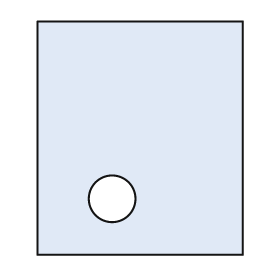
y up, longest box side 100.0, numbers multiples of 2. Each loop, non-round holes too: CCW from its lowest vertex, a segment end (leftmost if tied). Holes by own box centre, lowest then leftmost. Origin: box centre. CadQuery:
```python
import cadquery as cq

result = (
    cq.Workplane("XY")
    .moveTo(-44.0, -50.0)
    .lineTo(44.0, -50.0)
    .lineTo(44.0, 50.0)
    .lineTo(-44.0, 50.0)
    .close()
    .moveTo(-12.0, -26.0)
    .circle(10.0)
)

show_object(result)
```